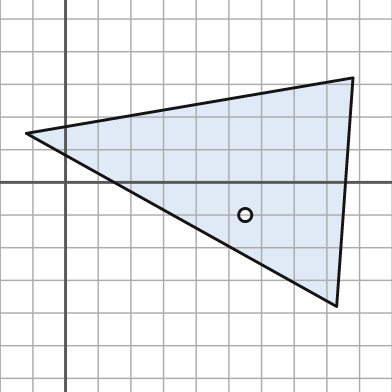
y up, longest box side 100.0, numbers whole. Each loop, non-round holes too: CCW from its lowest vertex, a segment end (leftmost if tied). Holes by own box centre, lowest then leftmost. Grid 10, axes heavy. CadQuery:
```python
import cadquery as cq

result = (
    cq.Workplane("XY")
    .moveTo(83.0, -38.0)
    .lineTo(88.0, 32.0)
    .lineTo(-12.0, 15.0)
    .close()
    .moveTo(55.0, -10.0)
    .circle(2.0)
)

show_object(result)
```